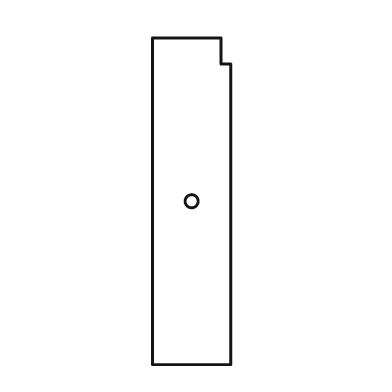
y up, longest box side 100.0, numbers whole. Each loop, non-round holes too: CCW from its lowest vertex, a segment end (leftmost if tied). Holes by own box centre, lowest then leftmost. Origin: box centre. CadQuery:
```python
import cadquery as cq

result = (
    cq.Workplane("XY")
    .moveTo(-12.0, -50.0)
    .lineTo(12.0, -50.0)
    .lineTo(12.0, 42.0)
    .lineTo(9.0, 42.0)
    .lineTo(9.0, 50.0)
    .lineTo(-12.0, 50.0)
    .close()
    .moveTo(0.0, 0.0)
    .circle(2.0)
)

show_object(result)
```